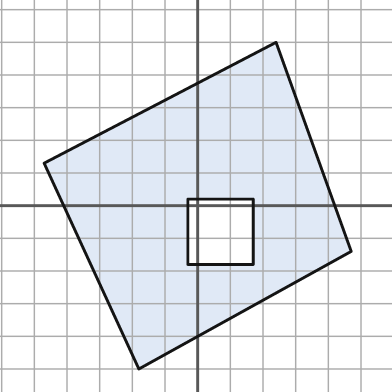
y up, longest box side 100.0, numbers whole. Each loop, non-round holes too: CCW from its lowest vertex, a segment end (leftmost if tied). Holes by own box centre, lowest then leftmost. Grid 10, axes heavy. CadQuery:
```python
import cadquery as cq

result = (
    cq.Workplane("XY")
    .moveTo(-18.0, -50.0)
    .lineTo(47.0, -14.0)
    .lineTo(24.0, 50.0)
    .lineTo(-47.0, 13.0)
    .close()
    .moveTo(-3.0, -18.0)
    .lineTo(17.0, -18.0)
    .lineTo(17.0, 2.0)
    .lineTo(-3.0, 2.0)
    .close()
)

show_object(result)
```